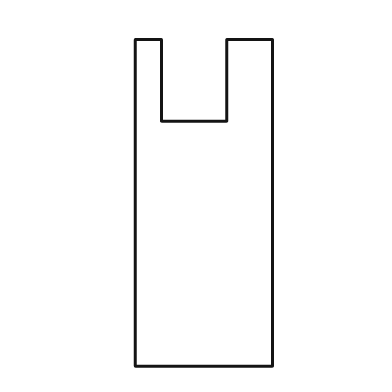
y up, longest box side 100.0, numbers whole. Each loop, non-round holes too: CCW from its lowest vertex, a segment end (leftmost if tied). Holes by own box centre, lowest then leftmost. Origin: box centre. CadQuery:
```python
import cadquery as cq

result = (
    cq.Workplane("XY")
    .moveTo(-21.0, -50.0)
    .lineTo(21.0, -50.0)
    .lineTo(21.0, 50.0)
    .lineTo(7.0, 50.0)
    .lineTo(7.0, 25.0)
    .lineTo(-13.0, 25.0)
    .lineTo(-13.0, 50.0)
    .lineTo(-21.0, 50.0)
    .close()
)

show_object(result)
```